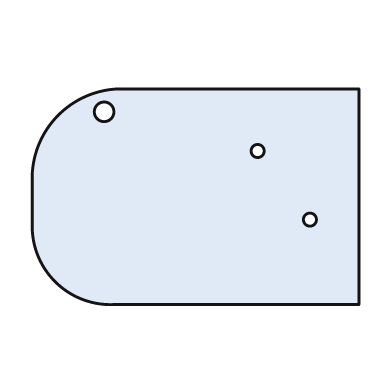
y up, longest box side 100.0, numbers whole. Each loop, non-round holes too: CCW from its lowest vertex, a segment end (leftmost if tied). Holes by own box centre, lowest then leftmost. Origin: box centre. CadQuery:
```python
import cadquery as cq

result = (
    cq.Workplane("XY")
    .moveTo(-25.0, -33.0)
    .lineTo(50.0, -33.0)
    .lineTo(50.0, 33.0)
    .lineTo(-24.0, 33.0)
    .threePointArc((-42.0, 25.0), (-50.0, 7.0))
    .lineTo(-50.0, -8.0)
    .threePointArc((-43.0, -26.0), (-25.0, -33.0))
    .close()
    .moveTo(35.0, -7.0)
    .circle(2.0)
    .moveTo(19.0, 14.0)
    .circle(2.0)
    .moveTo(-28.0, 26.0)
    .circle(3.0)
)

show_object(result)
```